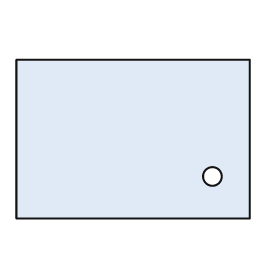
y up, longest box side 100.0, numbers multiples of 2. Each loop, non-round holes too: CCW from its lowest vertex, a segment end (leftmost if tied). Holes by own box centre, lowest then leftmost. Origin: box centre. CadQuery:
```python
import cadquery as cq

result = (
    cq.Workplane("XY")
    .moveTo(-50.0, -34.0)
    .lineTo(50.0, -34.0)
    .lineTo(50.0, 34.0)
    .lineTo(-50.0, 34.0)
    .close()
    .moveTo(34.0, -16.0)
    .circle(4.0)
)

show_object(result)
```